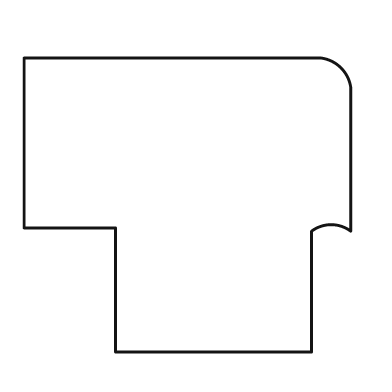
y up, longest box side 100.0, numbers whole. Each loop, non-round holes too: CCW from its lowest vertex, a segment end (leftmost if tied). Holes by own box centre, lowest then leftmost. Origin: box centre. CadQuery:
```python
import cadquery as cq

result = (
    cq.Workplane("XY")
    .moveTo(-22.0, -45.0)
    .lineTo(38.0, -45.0)
    .lineTo(38.0, -8.0)
    .threePointArc((44.0, -6.0), (50.0, -8.0))
    .lineTo(50.0, 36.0)
    .threePointArc((47.0, 42.0), (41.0, 45.0))
    .lineTo(-50.0, 45.0)
    .lineTo(-50.0, -7.0)
    .lineTo(-22.0, -7.0)
    .close()
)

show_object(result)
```